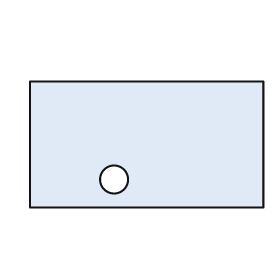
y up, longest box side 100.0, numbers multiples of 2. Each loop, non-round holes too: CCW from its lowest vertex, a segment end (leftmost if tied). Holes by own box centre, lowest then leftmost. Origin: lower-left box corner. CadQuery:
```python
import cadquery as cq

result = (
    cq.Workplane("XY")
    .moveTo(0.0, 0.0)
    .lineTo(100.0, 0.0)
    .lineTo(100.0, 54.0)
    .lineTo(0.0, 54.0)
    .close()
    .moveTo(36.0, 12.0)
    .circle(6.0)
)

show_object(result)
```